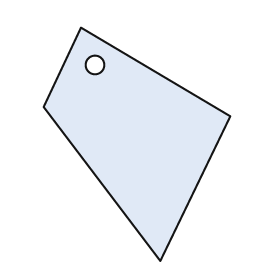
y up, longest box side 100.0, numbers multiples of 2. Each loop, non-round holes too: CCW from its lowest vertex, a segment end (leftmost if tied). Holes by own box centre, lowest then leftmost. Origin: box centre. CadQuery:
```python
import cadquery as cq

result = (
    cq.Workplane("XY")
    .moveTo(10.0, -50.0)
    .lineTo(40.0, 12.0)
    .lineTo(-24.0, 50.0)
    .lineTo(-40.0, 16.0)
    .close()
    .moveTo(-18.0, 34.0)
    .circle(4.0)
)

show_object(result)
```